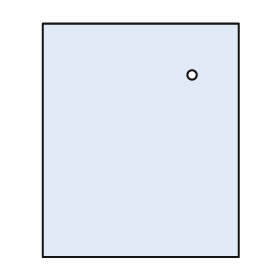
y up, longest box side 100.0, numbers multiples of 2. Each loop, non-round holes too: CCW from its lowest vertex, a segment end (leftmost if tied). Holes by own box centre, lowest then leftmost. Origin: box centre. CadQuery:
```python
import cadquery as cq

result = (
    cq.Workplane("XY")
    .moveTo(-42.0, -50.0)
    .lineTo(42.0, -50.0)
    .lineTo(42.0, 50.0)
    .lineTo(-42.0, 50.0)
    .close()
    .moveTo(22.0, 28.0)
    .circle(2.0)
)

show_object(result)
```